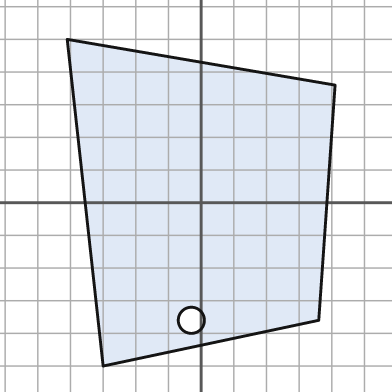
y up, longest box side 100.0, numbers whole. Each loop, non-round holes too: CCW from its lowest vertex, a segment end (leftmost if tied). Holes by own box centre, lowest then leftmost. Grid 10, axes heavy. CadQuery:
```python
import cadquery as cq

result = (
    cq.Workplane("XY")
    .moveTo(-30.0, -50.0)
    .lineTo(36.0, -36.0)
    .lineTo(41.0, 36.0)
    .lineTo(-41.0, 50.0)
    .close()
    .moveTo(-3.0, -36.0)
    .circle(4.0)
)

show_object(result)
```